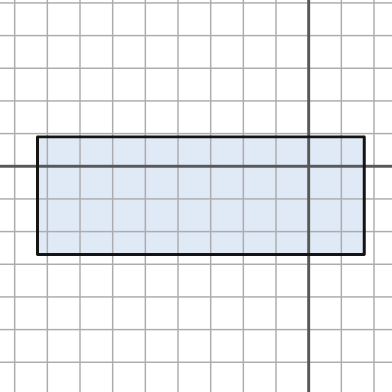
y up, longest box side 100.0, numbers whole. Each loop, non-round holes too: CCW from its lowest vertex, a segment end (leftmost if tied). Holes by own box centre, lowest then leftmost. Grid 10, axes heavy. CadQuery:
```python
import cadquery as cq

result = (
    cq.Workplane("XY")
    .moveTo(-83.0, -27.0)
    .lineTo(17.0, -27.0)
    .lineTo(17.0, 9.0)
    .lineTo(-83.0, 9.0)
    .close()
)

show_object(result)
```